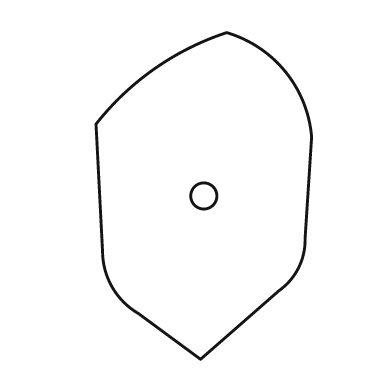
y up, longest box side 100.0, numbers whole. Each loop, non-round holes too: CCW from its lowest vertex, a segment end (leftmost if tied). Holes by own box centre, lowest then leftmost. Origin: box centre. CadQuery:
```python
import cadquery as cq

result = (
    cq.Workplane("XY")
    .moveTo(-1.0, -50.0)
    .lineTo(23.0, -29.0)
    .threePointArc((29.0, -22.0), (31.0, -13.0))
    .lineTo(33.0, 18.0)
    .threePointArc((25.0, 38.0), (7.0, 50.0))
    .threePointArc((-15.0, 39.0), (-33.0, 22.0))
    .lineTo(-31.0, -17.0)
    .threePointArc((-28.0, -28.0), (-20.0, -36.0))
    .close()
    .moveTo(0.0, 0.0)
    .circle(4.0)
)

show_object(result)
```